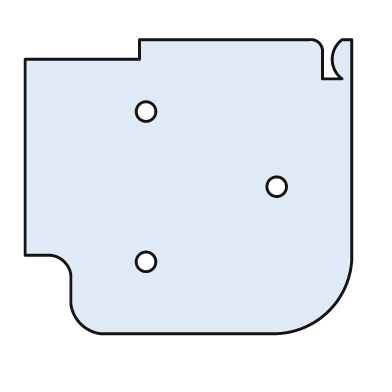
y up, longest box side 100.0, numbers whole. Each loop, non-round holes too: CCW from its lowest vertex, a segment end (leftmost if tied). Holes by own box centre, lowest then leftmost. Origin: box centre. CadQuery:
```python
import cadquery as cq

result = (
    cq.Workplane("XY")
    .moveTo(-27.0, -45.0)
    .lineTo(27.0, -45.0)
    .threePointArc((43.0, -38.0), (50.0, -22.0))
    .lineTo(50.0, 45.0)
    .lineTo(47.0, 45.0)
    .threePointArc((44.0, 39.0), (47.0, 33.0))
    .lineTo(41.0, 33.0)
    .lineTo(41.0, 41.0)
    .threePointArc((40.0, 44.0), (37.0, 45.0))
    .lineTo(-15.0, 45.0)
    .lineTo(-15.0, 39.0)
    .lineTo(-50.0, 39.0)
    .lineTo(-50.0, -21.0)
    .lineTo(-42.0, -21.0)
    .threePointArc((-38.0, -23.0), (-36.0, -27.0))
    .lineTo(-36.0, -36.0)
    .threePointArc((-33.0, -42.0), (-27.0, -45.0))
    .close()
    .moveTo(-13.0, -23.0)
    .circle(3.0)
    .moveTo(27.0, 0.0)
    .circle(3.0)
    .moveTo(-13.0, 23.0)
    .circle(3.0)
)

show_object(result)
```